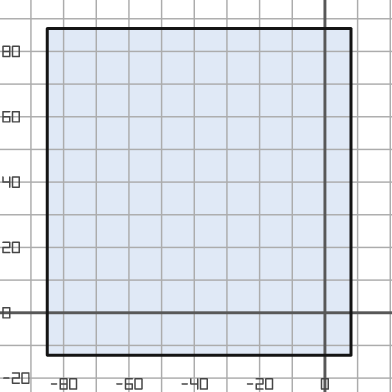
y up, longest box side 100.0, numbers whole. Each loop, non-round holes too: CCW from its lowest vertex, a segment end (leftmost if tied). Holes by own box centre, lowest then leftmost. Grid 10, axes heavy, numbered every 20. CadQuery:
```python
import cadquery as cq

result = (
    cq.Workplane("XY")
    .moveTo(-85.0, -13.0)
    .lineTo(8.0, -13.0)
    .lineTo(8.0, 87.0)
    .lineTo(-85.0, 87.0)
    .close()
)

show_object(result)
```